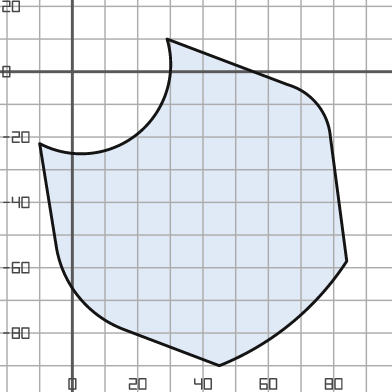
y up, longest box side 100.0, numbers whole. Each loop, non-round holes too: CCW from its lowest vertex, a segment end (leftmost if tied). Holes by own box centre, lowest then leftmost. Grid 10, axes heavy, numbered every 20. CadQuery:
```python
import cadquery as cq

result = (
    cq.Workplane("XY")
    .moveTo(45.0, -90.0)
    .threePointArc((67.0, -77.0), (84.0, -58.0))
    .lineTo(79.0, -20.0)
    .threePointArc((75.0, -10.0), (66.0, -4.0))
    .lineTo(29.0, 10.0)
    .threePointArc((20.0, -19.0), (-10.0, -22.0))
    .lineTo(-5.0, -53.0)
    .threePointArc((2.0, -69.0), (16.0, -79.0))
    .close()
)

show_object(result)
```